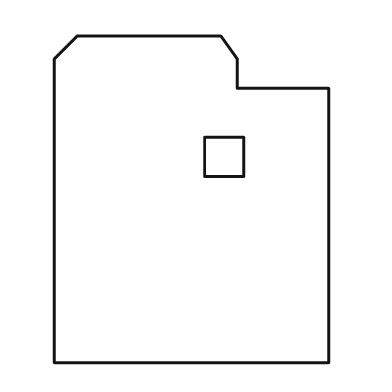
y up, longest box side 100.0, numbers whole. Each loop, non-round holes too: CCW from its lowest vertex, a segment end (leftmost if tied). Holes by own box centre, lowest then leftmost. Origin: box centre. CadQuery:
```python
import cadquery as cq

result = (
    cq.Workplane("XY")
    .moveTo(-42.0, -50.0)
    .lineTo(42.0, -50.0)
    .lineTo(42.0, 34.0)
    .lineTo(14.0, 34.0)
    .lineTo(14.0, 43.0)
    .lineTo(9.0, 50.0)
    .lineTo(-35.0, 50.0)
    .lineTo(-42.0, 43.0)
    .close()
    .moveTo(4.0, 7.0)
    .lineTo(16.0, 7.0)
    .lineTo(16.0, 19.0)
    .lineTo(4.0, 19.0)
    .close()
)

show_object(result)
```